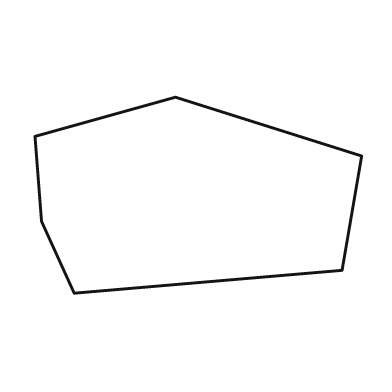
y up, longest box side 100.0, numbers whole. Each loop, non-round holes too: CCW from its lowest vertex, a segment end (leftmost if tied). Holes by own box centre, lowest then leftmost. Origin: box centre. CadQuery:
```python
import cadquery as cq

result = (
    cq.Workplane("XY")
    .moveTo(-38.0, -30.0)
    .lineTo(44.0, -23.0)
    .lineTo(50.0, 12.0)
    .lineTo(-7.0, 30.0)
    .lineTo(-50.0, 18.0)
    .lineTo(-48.0, -8.0)
    .close()
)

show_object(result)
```